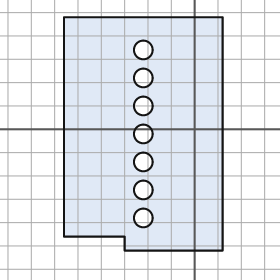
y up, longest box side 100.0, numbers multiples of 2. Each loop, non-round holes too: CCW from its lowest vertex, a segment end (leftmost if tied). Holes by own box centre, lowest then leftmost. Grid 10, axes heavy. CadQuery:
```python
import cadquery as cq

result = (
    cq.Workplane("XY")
    .moveTo(-30.0, -52.0)
    .lineTo(12.0, -52.0)
    .lineTo(12.0, 48.0)
    .lineTo(-56.0, 48.0)
    .lineTo(-56.0, -46.0)
    .lineTo(-30.0, -46.0)
    .close()
    .moveTo(-22.0, -38.0)
    .circle(4.0)
    .moveTo(-22.0, -26.0)
    .circle(4.0)
    .moveTo(-22.0, -14.0)
    .circle(4.0)
    .moveTo(-22.0, -2.0)
    .circle(4.0)
    .moveTo(-22.0, 10.0)
    .circle(4.0)
    .moveTo(-22.0, 22.0)
    .circle(4.0)
    .moveTo(-22.0, 34.0)
    .circle(4.0)
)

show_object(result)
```